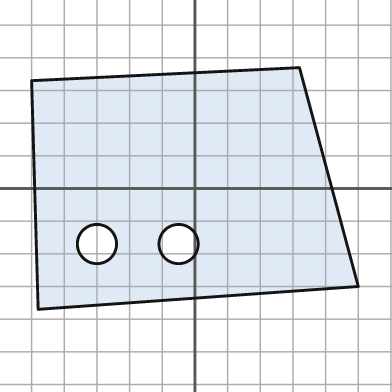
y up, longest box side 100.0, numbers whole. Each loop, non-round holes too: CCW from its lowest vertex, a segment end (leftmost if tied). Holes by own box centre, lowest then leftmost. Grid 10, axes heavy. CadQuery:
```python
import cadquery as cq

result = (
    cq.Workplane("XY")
    .moveTo(-48.0, -37.0)
    .lineTo(50.0, -30.0)
    .lineTo(32.0, 37.0)
    .lineTo(-50.0, 33.0)
    .close()
    .moveTo(-30.0, -17.0)
    .circle(6.0)
    .moveTo(-5.0, -17.0)
    .circle(6.0)
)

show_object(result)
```